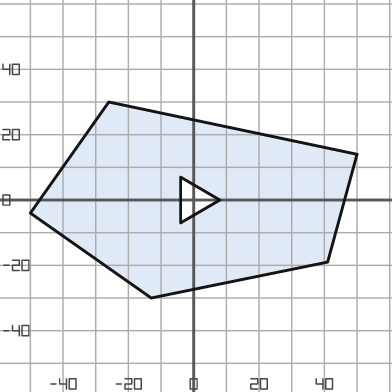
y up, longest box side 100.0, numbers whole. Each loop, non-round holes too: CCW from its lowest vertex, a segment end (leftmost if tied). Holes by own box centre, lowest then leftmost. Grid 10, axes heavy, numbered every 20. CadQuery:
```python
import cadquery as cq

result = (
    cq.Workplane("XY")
    .moveTo(-13.0, -30.0)
    .lineTo(41.0, -19.0)
    .lineTo(50.0, 14.0)
    .lineTo(-26.0, 30.0)
    .lineTo(-50.0, -4.0)
    .close()
    .moveTo(-4.0, -7.0)
    .lineTo(8.0, 0.0)
    .lineTo(-4.0, 7.0)
    .close()
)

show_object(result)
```